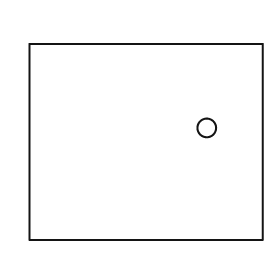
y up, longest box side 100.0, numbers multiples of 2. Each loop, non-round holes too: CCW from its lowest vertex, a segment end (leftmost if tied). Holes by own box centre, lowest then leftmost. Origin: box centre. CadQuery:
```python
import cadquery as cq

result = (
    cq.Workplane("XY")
    .moveTo(-50.0, -42.0)
    .lineTo(50.0, -42.0)
    .lineTo(50.0, 42.0)
    .lineTo(-50.0, 42.0)
    .close()
    .moveTo(26.0, 6.0)
    .circle(4.0)
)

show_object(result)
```